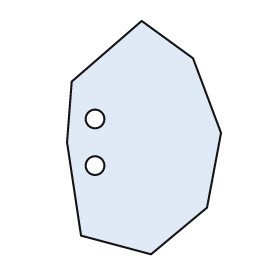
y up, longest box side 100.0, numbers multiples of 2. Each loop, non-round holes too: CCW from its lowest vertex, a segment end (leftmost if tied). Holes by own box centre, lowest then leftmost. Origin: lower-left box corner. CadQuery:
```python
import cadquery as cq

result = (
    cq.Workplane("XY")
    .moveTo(36.0, 0.0)
    .lineTo(60.0, 20.0)
    .lineTo(66.0, 52.0)
    .lineTo(54.0, 84.0)
    .lineTo(32.0, 100.0)
    .lineTo(2.0, 74.0)
    .lineTo(0.0, 48.0)
    .lineTo(6.0, 8.0)
    .close()
    .moveTo(12.0, 38.0)
    .circle(4.0)
    .moveTo(12.0, 58.0)
    .circle(4.0)
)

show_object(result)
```